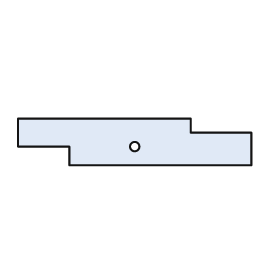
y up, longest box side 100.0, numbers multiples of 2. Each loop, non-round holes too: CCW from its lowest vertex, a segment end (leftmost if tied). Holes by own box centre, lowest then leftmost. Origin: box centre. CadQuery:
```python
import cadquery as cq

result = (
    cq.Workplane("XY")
    .moveTo(-28.0, -10.0)
    .lineTo(50.0, -10.0)
    .lineTo(50.0, 4.0)
    .lineTo(24.0, 4.0)
    .lineTo(24.0, 10.0)
    .lineTo(-50.0, 10.0)
    .lineTo(-50.0, -2.0)
    .lineTo(-28.0, -2.0)
    .close()
    .moveTo(0.0, -2.0)
    .circle(2.0)
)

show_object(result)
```